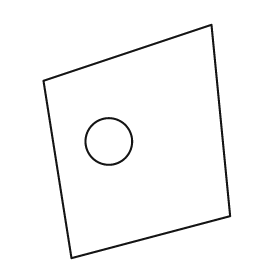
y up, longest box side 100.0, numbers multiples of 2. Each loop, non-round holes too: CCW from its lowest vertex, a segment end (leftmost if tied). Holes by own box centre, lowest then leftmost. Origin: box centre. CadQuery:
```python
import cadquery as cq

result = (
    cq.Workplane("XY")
    .moveTo(-28.0, -50.0)
    .lineTo(40.0, -32.0)
    .lineTo(32.0, 50.0)
    .lineTo(-40.0, 26.0)
    .close()
    .moveTo(-12.0, 0.0)
    .circle(10.0)
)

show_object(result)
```